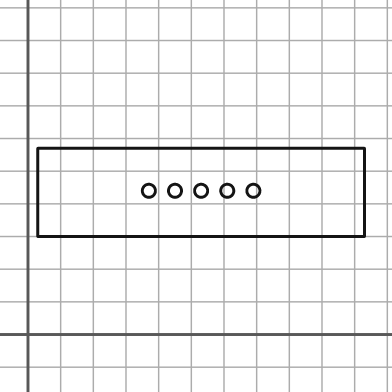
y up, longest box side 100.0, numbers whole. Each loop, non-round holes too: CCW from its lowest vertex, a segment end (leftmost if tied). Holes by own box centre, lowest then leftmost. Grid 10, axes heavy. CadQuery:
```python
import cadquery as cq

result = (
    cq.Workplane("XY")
    .moveTo(3.0, 30.0)
    .lineTo(103.0, 30.0)
    .lineTo(103.0, 57.0)
    .lineTo(3.0, 57.0)
    .close()
    .moveTo(37.0, 44.0)
    .circle(2.0)
    .moveTo(45.0, 44.0)
    .circle(2.0)
    .moveTo(53.0, 44.0)
    .circle(2.0)
    .moveTo(61.0, 44.0)
    .circle(2.0)
    .moveTo(69.0, 44.0)
    .circle(2.0)
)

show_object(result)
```